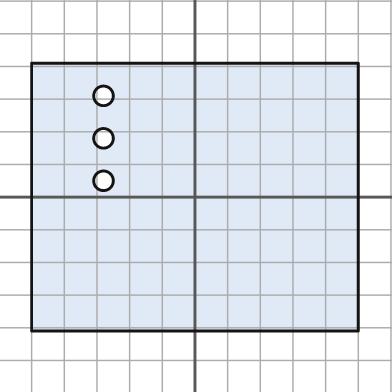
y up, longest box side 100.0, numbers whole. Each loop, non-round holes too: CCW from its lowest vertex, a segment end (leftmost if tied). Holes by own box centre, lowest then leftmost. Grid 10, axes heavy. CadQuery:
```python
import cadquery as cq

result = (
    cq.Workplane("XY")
    .moveTo(-50.0, -41.0)
    .lineTo(50.0, -41.0)
    .lineTo(50.0, 41.0)
    .lineTo(-50.0, 41.0)
    .close()
    .moveTo(-28.0, 5.0)
    .circle(3.0)
    .moveTo(-28.0, 18.0)
    .circle(3.0)
    .moveTo(-28.0, 31.0)
    .circle(3.0)
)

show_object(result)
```